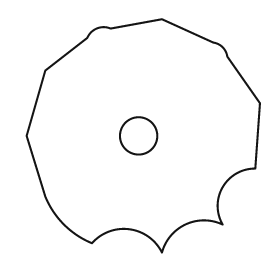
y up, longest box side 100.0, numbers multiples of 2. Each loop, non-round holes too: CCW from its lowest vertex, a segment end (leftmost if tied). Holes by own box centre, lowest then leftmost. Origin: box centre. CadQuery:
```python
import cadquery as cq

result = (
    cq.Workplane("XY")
    .moveTo(8.0, -50.0)
    .threePointArc((18.0, -38.0), (34.0, -38.0))
    .threePointArc((34.0, -22.0), (48.0, -14.0))
    .lineTo(50.0, 14.0)
    .lineTo(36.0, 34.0)
    .threePointArc((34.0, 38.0), (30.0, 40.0))
    .lineTo(8.0, 50.0)
    .lineTo(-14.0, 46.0)
    .threePointArc((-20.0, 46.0), (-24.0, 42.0))
    .lineTo(-42.0, 28.0)
    .lineTo(-50.0, 0.0)
    .lineTo(-42.0, -26.0)
    .threePointArc((-34.0, -38.0), (-22.0, -46.0))
    .threePointArc((-6.0, -40.0), (8.0, -50.0))
    .close()
    .moveTo(-2.0, 0.0)
    .circle(8.0)
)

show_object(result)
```